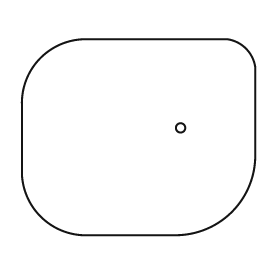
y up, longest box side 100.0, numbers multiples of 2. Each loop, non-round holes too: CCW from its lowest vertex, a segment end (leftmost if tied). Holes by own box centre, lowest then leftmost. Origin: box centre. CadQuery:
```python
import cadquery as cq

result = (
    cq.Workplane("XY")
    .moveTo(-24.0, -42.0)
    .lineTo(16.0, -42.0)
    .threePointArc((40.0, -32.0), (50.0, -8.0))
    .lineTo(50.0, 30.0)
    .threePointArc((46.0, 38.0), (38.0, 42.0))
    .lineTo(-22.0, 42.0)
    .threePointArc((-42.0, 34.0), (-50.0, 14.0))
    .lineTo(-50.0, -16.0)
    .threePointArc((-42.0, -34.0), (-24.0, -42.0))
    .close()
    .moveTo(18.0, 4.0)
    .circle(2.0)
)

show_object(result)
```